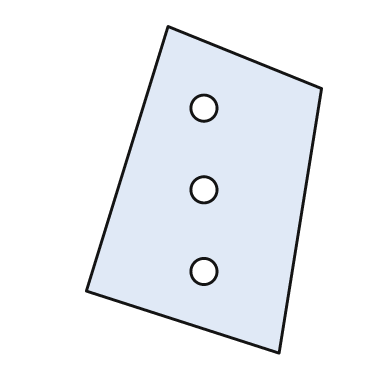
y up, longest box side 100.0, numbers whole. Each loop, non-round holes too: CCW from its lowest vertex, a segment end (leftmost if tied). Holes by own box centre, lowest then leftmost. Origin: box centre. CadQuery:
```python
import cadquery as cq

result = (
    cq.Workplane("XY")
    .moveTo(23.0, -50.0)
    .lineTo(36.0, 31.0)
    .lineTo(-11.0, 50.0)
    .lineTo(-36.0, -31.0)
    .close()
    .moveTo(0.0, -25.0)
    .circle(4.0)
    .moveTo(0.0, 0.0)
    .circle(4.0)
    .moveTo(0.0, 25.0)
    .circle(4.0)
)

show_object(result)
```